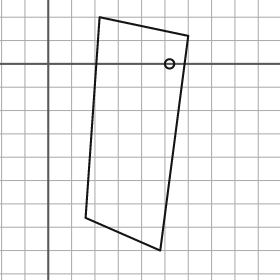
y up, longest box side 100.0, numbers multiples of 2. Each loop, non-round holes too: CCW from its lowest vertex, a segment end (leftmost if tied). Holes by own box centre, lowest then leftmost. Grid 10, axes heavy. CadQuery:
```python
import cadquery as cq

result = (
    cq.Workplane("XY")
    .moveTo(48.0, -80.0)
    .lineTo(60.0, 12.0)
    .lineTo(22.0, 20.0)
    .lineTo(16.0, -66.0)
    .close()
    .moveTo(52.0, 0.0)
    .circle(2.0)
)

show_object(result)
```